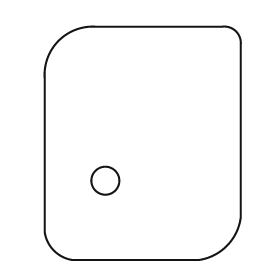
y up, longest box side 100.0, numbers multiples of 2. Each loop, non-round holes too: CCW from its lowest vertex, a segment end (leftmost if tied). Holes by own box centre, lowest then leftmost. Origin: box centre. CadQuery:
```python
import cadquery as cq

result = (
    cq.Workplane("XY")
    .moveTo(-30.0, -50.0)
    .lineTo(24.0, -50.0)
    .threePointArc((36.0, -44.0), (42.0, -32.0))
    .lineTo(42.0, 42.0)
    .threePointArc((40.0, 48.0), (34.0, 50.0))
    .lineTo(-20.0, 50.0)
    .threePointArc((-36.0, 44.0), (-42.0, 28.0))
    .lineTo(-42.0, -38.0)
    .threePointArc((-38.0, -46.0), (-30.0, -50.0))
    .close()
    .moveTo(-16.0, -16.0)
    .circle(6.0)
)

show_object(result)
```